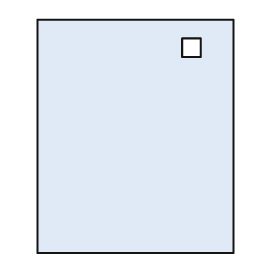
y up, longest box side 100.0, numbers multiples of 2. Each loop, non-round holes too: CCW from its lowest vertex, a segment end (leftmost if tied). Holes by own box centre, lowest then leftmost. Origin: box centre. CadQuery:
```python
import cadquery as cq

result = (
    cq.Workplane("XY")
    .moveTo(-42.0, -50.0)
    .lineTo(42.0, -50.0)
    .lineTo(42.0, 50.0)
    .lineTo(-42.0, 50.0)
    .close()
    .moveTo(20.0, 34.0)
    .lineTo(28.0, 34.0)
    .lineTo(28.0, 42.0)
    .lineTo(20.0, 42.0)
    .close()
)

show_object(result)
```